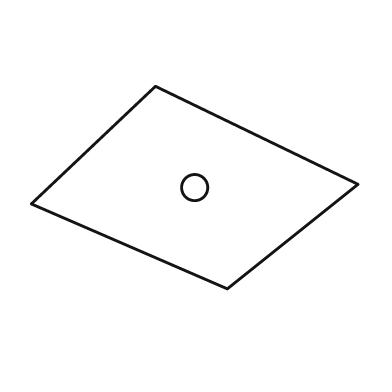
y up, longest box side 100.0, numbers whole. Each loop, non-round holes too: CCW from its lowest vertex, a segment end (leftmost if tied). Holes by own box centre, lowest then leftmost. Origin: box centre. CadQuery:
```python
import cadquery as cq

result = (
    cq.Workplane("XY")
    .moveTo(10.0, -31.0)
    .lineTo(50.0, 1.0)
    .lineTo(-12.0, 31.0)
    .lineTo(-50.0, -5.0)
    .close()
    .moveTo(0.0, 0.0)
    .circle(4.0)
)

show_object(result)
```